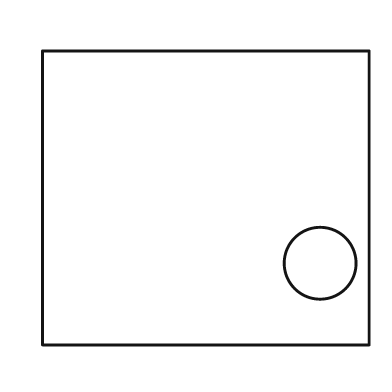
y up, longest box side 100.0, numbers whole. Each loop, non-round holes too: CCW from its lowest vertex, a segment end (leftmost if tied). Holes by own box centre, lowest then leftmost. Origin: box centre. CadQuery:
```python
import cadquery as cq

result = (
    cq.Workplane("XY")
    .moveTo(-50.0, -45.0)
    .lineTo(50.0, -45.0)
    .lineTo(50.0, 45.0)
    .lineTo(-50.0, 45.0)
    .close()
    .moveTo(35.0, -20.0)
    .circle(11.0)
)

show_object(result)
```